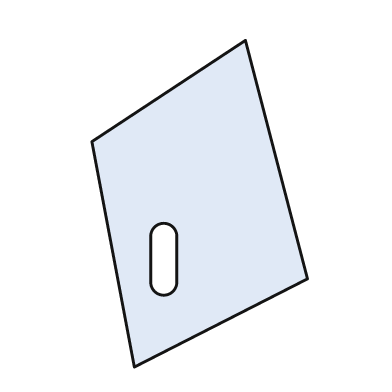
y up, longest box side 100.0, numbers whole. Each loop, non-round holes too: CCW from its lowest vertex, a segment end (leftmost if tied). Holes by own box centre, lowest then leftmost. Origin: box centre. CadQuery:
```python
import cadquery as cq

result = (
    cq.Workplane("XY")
    .moveTo(-20.0, -50.0)
    .lineTo(33.0, -23.0)
    .lineTo(14.0, 50.0)
    .lineTo(-33.0, 19.0)
    .close()
    .moveTo(-15.0, -24.0)
    .threePointArc((-11.0, -28.0), (-7.0, -24.0))
    .lineTo(-7.0, -10.0)
    .threePointArc((-11.0, -6.0), (-15.0, -10.0))
    .close()
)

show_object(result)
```